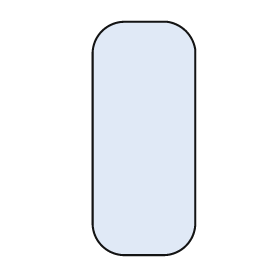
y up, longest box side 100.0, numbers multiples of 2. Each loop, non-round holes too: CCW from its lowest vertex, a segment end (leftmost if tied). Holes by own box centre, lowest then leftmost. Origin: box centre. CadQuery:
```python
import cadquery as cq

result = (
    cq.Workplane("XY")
    .moveTo(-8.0, -50.0)
    .lineTo(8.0, -50.0)
    .threePointArc((18.0, -46.0), (22.0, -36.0))
    .lineTo(22.0, 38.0)
    .threePointArc((18.0, 46.0), (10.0, 50.0))
    .lineTo(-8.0, 50.0)
    .threePointArc((-18.0, 46.0), (-22.0, 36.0))
    .lineTo(-22.0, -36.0)
    .threePointArc((-18.0, -46.0), (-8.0, -50.0))
    .close()
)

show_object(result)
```